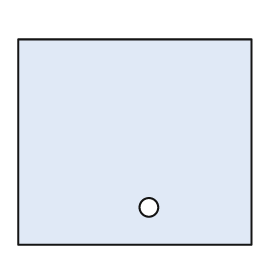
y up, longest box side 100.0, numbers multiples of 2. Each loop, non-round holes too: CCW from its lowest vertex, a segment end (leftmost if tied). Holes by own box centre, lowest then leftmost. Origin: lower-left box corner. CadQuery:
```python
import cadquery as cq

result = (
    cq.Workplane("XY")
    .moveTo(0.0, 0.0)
    .lineTo(100.0, 0.0)
    .lineTo(100.0, 88.0)
    .lineTo(0.0, 88.0)
    .close()
    .moveTo(56.0, 16.0)
    .circle(4.0)
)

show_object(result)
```